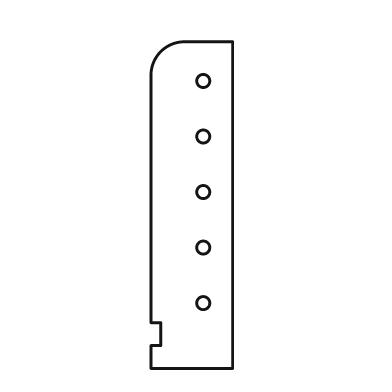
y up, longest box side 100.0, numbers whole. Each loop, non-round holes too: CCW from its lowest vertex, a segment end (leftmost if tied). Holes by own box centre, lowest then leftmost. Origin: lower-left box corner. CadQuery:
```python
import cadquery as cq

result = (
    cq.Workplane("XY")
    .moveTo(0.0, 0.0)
    .lineTo(25.0, 0.0)
    .lineTo(25.0, 100.0)
    .lineTo(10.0, 100.0)
    .threePointArc((3.0, 97.0), (0.0, 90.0))
    .lineTo(0.0, 14.0)
    .lineTo(3.0, 14.0)
    .lineTo(3.0, 7.0)
    .lineTo(0.0, 7.0)
    .close()
    .moveTo(16.0, 20.0)
    .circle(2.0)
    .moveTo(16.0, 37.0)
    .circle(2.0)
    .moveTo(16.0, 54.0)
    .circle(2.0)
    .moveTo(16.0, 71.0)
    .circle(2.0)
    .moveTo(16.0, 88.0)
    .circle(2.0)
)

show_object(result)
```